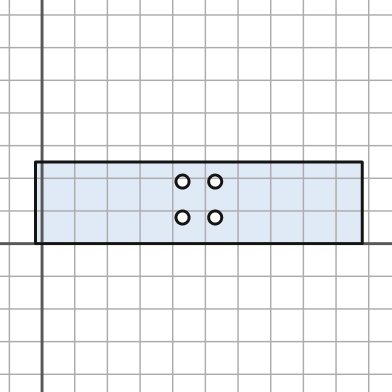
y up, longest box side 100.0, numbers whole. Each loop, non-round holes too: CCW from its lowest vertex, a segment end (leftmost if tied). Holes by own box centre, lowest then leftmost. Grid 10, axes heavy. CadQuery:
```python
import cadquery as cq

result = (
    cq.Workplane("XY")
    .moveTo(-2.0, 0.0)
    .lineTo(98.0, 0.0)
    .lineTo(98.0, 25.0)
    .lineTo(-2.0, 25.0)
    .close()
    .moveTo(43.0, 8.0)
    .circle(2.0)
    .moveTo(53.0, 8.0)
    .circle(2.0)
    .moveTo(43.0, 19.0)
    .circle(2.0)
    .moveTo(53.0, 19.0)
    .circle(2.0)
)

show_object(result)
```